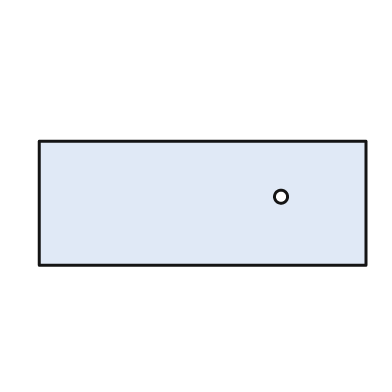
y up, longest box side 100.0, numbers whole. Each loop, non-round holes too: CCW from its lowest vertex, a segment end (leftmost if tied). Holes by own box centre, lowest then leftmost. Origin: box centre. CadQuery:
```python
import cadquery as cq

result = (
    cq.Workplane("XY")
    .moveTo(-50.0, -19.0)
    .lineTo(50.0, -19.0)
    .lineTo(50.0, 19.0)
    .lineTo(-50.0, 19.0)
    .close()
    .moveTo(24.0, 2.0)
    .circle(2.0)
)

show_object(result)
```